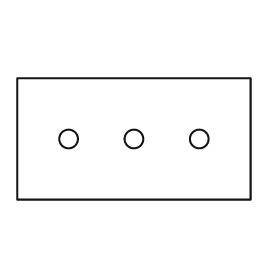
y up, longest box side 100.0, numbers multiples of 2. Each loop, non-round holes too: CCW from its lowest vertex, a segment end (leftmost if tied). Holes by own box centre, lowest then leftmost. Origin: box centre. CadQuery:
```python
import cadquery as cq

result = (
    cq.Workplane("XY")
    .moveTo(-50.0, -26.0)
    .lineTo(50.0, -26.0)
    .lineTo(50.0, 26.0)
    .lineTo(-50.0, 26.0)
    .close()
    .moveTo(-28.0, 0.0)
    .circle(4.0)
    .moveTo(0.0, 0.0)
    .circle(4.0)
    .moveTo(28.0, 0.0)
    .circle(4.0)
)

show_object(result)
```